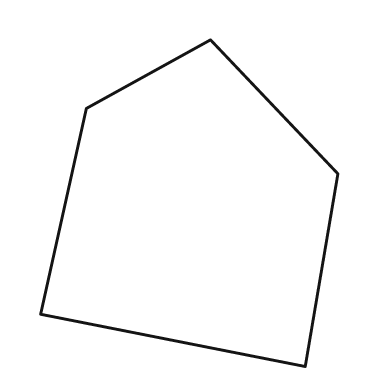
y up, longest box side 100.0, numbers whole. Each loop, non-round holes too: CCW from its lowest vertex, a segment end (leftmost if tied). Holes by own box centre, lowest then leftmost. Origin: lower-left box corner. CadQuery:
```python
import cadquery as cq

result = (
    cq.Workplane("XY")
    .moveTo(81.0, 0.0)
    .lineTo(91.0, 59.0)
    .lineTo(52.0, 100.0)
    .lineTo(14.0, 79.0)
    .lineTo(0.0, 16.0)
    .close()
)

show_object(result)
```